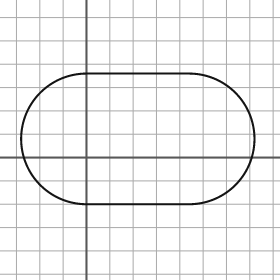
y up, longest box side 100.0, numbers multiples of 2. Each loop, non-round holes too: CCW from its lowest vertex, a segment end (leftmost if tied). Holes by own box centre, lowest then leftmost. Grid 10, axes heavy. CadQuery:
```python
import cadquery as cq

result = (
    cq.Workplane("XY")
    .moveTo(0.0, -20.0)
    .lineTo(44.0, -20.0)
    .threePointArc((72.0, 8.0), (44.0, 36.0))
    .lineTo(0.0, 36.0)
    .threePointArc((-28.0, 8.0), (0.0, -20.0))
    .close()
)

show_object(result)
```